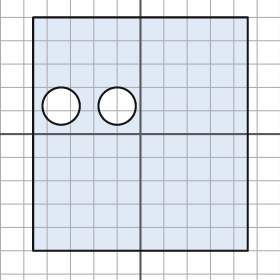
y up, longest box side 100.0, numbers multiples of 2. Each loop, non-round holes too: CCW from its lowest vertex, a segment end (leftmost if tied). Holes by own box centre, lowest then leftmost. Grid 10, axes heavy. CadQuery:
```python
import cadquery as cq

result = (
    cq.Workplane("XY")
    .moveTo(-46.0, -50.0)
    .lineTo(46.0, -50.0)
    .lineTo(46.0, 50.0)
    .lineTo(-46.0, 50.0)
    .close()
    .moveTo(-34.0, 12.0)
    .circle(8.0)
    .moveTo(-10.0, 12.0)
    .circle(8.0)
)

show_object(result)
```